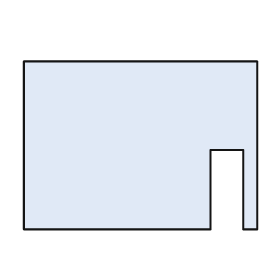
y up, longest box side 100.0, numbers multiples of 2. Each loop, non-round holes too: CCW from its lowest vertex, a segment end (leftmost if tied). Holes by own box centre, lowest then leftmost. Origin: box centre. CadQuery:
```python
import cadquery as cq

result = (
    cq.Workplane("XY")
    .moveTo(-50.0, -36.0)
    .lineTo(30.0, -36.0)
    .lineTo(30.0, -2.0)
    .lineTo(44.0, -2.0)
    .lineTo(44.0, -36.0)
    .lineTo(50.0, -36.0)
    .lineTo(50.0, 36.0)
    .lineTo(-50.0, 36.0)
    .close()
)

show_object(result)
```